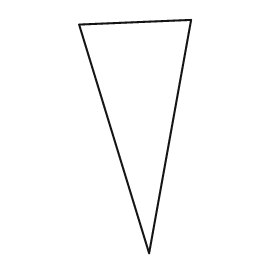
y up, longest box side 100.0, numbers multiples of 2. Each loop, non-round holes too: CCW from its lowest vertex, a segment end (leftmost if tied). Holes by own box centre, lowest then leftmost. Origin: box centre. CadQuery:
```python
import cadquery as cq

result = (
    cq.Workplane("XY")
    .moveTo(6.0, -50.0)
    .lineTo(24.0, 50.0)
    .lineTo(-24.0, 48.0)
    .close()
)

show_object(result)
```